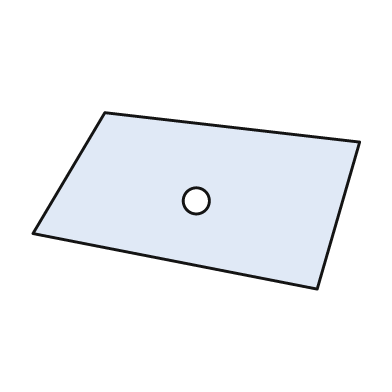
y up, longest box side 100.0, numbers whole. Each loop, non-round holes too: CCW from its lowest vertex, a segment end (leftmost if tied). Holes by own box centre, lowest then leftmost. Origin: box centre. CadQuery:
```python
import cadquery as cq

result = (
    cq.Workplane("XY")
    .moveTo(37.0, -27.0)
    .lineTo(50.0, 18.0)
    .lineTo(-28.0, 27.0)
    .lineTo(-50.0, -10.0)
    .close()
    .moveTo(0.0, 0.0)
    .circle(4.0)
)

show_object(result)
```